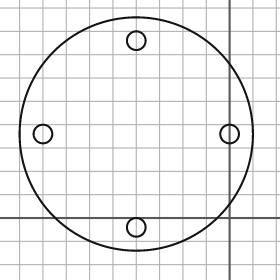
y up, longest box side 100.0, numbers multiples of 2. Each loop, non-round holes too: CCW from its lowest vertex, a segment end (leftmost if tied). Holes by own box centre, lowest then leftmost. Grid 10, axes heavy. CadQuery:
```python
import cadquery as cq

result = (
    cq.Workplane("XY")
    .moveTo(-40.0, 36.0)
    .circle(50.0)
    .moveTo(-40.0, -4.0)
    .circle(4.0)
    .moveTo(-80.0, 36.0)
    .circle(4.0)
    .moveTo(0.0, 36.0)
    .circle(4.0)
    .moveTo(-40.0, 76.0)
    .circle(4.0)
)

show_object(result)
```